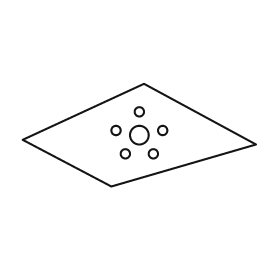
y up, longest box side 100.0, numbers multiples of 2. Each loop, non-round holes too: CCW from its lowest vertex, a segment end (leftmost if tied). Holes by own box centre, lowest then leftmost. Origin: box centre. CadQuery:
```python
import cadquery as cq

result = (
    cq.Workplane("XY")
    .moveTo(-12.0, -22.0)
    .lineTo(50.0, -4.0)
    .lineTo(2.0, 22.0)
    .lineTo(-50.0, -2.0)
    .close()
    .moveTo(-6.0, -8.0)
    .circle(2.0)
    .moveTo(6.0, -8.0)
    .circle(2.0)
    .moveTo(0.0, 0.0)
    .circle(4.0)
    .moveTo(-10.0, 2.0)
    .circle(2.0)
    .moveTo(10.0, 2.0)
    .circle(2.0)
    .moveTo(0.0, 10.0)
    .circle(2.0)
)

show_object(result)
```